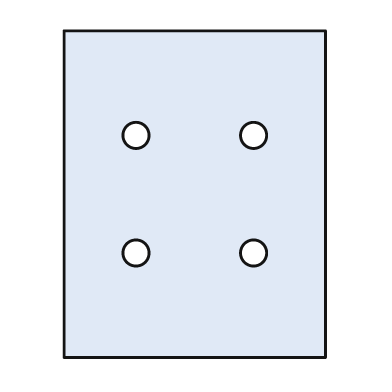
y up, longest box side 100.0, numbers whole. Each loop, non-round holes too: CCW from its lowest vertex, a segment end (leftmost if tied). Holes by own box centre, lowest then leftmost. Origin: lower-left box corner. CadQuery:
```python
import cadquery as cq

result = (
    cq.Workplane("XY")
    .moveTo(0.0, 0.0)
    .lineTo(80.0, 0.0)
    .lineTo(80.0, 100.0)
    .lineTo(0.0, 100.0)
    .close()
    .moveTo(22.0, 32.0)
    .circle(4.0)
    .moveTo(58.0, 32.0)
    .circle(4.0)
    .moveTo(22.0, 68.0)
    .circle(4.0)
    .moveTo(58.0, 68.0)
    .circle(4.0)
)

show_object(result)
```